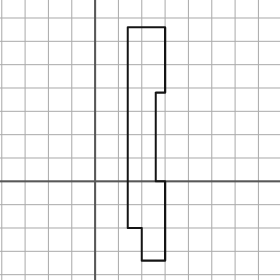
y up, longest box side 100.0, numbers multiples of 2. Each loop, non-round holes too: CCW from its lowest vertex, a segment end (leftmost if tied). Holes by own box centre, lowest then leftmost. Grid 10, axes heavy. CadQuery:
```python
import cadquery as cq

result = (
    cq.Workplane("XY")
    .moveTo(20.0, -34.0)
    .lineTo(30.0, -34.0)
    .lineTo(30.0, 0.0)
    .lineTo(26.0, 0.0)
    .lineTo(26.0, 38.0)
    .lineTo(30.0, 38.0)
    .lineTo(30.0, 66.0)
    .lineTo(14.0, 66.0)
    .lineTo(14.0, -20.0)
    .lineTo(20.0, -20.0)
    .close()
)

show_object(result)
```